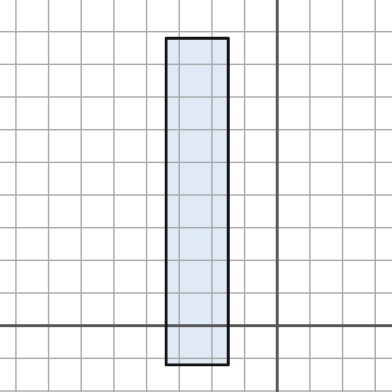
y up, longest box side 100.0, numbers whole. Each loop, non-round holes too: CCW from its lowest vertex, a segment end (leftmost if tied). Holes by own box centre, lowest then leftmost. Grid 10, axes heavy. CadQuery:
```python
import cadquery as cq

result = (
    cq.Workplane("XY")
    .moveTo(-34.0, -12.0)
    .lineTo(-15.0, -12.0)
    .lineTo(-15.0, 88.0)
    .lineTo(-34.0, 88.0)
    .close()
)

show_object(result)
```